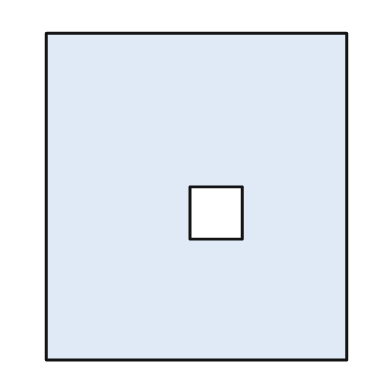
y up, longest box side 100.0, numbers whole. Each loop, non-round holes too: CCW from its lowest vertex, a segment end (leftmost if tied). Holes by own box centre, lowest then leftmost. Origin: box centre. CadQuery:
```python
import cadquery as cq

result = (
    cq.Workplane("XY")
    .moveTo(-46.0, -50.0)
    .lineTo(46.0, -50.0)
    .lineTo(46.0, 50.0)
    .lineTo(-46.0, 50.0)
    .close()
    .moveTo(-2.0, -13.0)
    .lineTo(14.0, -13.0)
    .lineTo(14.0, 3.0)
    .lineTo(-2.0, 3.0)
    .close()
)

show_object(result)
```